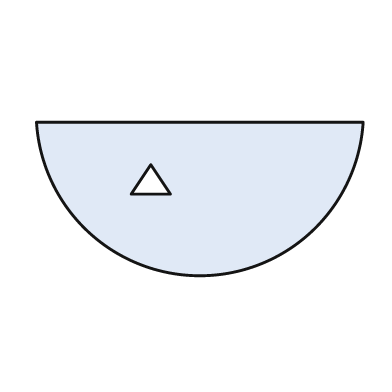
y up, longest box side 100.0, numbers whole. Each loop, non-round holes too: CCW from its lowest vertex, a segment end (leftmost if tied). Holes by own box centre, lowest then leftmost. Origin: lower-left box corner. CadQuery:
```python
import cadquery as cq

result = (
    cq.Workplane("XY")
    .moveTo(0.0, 47.0)
    .threePointArc((50.0, 0.0), (100.0, 47.0))
    .close()
    .moveTo(29.0, 25.0)
    .lineTo(41.0, 25.0)
    .lineTo(35.0, 34.0)
    .close()
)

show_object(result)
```